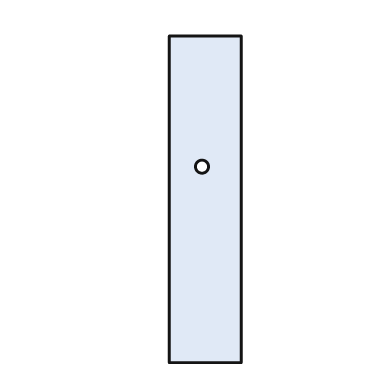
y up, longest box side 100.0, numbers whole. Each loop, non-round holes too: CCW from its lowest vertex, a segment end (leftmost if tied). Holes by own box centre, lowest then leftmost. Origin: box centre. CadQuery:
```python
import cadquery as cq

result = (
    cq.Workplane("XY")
    .moveTo(-11.0, -50.0)
    .lineTo(11.0, -50.0)
    .lineTo(11.0, 50.0)
    .lineTo(-11.0, 50.0)
    .close()
    .moveTo(-1.0, 10.0)
    .circle(2.0)
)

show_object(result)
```